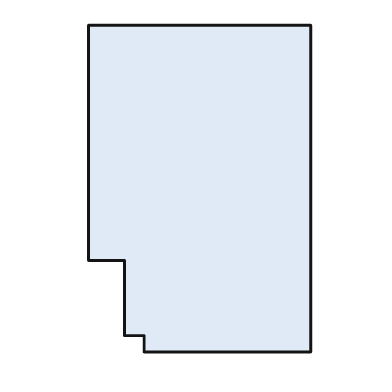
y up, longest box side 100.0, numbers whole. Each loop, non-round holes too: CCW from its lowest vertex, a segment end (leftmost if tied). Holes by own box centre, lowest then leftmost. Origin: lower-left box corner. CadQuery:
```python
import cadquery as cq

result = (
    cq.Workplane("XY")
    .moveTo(17.0, 0.0)
    .lineTo(68.0, 0.0)
    .lineTo(68.0, 100.0)
    .lineTo(0.0, 100.0)
    .lineTo(0.0, 28.0)
    .lineTo(11.0, 28.0)
    .lineTo(11.0, 5.0)
    .lineTo(17.0, 5.0)
    .close()
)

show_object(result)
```